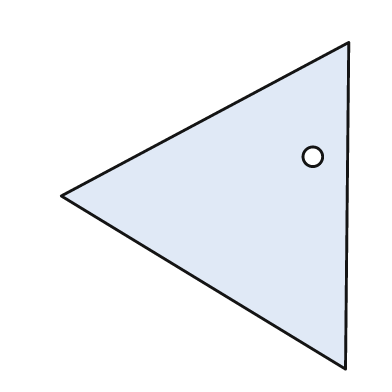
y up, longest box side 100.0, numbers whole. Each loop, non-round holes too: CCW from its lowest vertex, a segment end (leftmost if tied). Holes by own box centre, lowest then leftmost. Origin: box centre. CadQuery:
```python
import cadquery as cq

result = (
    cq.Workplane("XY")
    .moveTo(43.0, -50.0)
    .lineTo(44.0, 50.0)
    .lineTo(-44.0, 3.0)
    .close()
    .moveTo(33.0, 15.0)
    .circle(3.0)
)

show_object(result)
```